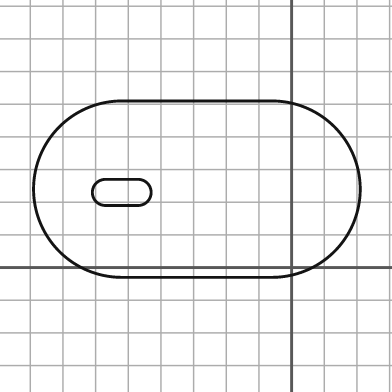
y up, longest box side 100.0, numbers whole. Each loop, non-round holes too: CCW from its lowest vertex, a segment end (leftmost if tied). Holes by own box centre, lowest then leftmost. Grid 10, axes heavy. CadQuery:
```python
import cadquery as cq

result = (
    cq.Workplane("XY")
    .moveTo(-52.0, -3.0)
    .lineTo(-6.0, -3.0)
    .threePointArc((21.0, 24.0), (-6.0, 51.0))
    .lineTo(-52.0, 51.0)
    .threePointArc((-79.0, 24.0), (-52.0, -3.0))
    .close()
    .moveTo(-57.0, 19.0)
    .lineTo(-47.0, 19.0)
    .threePointArc((-43.0, 23.0), (-47.0, 27.0))
    .lineTo(-57.0, 27.0)
    .threePointArc((-61.0, 23.0), (-57.0, 19.0))
    .close()
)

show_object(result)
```